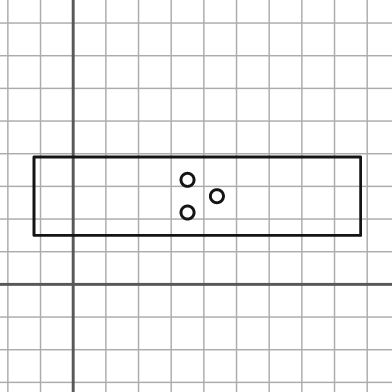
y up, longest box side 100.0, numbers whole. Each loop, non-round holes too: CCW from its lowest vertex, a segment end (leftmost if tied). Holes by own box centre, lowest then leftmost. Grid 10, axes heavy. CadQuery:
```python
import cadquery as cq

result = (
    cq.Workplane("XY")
    .moveTo(-12.0, 15.0)
    .lineTo(88.0, 15.0)
    .lineTo(88.0, 39.0)
    .lineTo(-12.0, 39.0)
    .close()
    .moveTo(35.0, 22.0)
    .circle(2.0)
    .moveTo(44.0, 27.0)
    .circle(2.0)
    .moveTo(35.0, 32.0)
    .circle(2.0)
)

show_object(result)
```